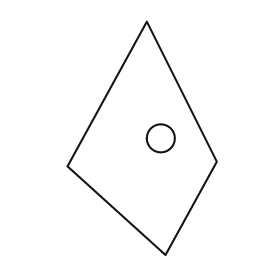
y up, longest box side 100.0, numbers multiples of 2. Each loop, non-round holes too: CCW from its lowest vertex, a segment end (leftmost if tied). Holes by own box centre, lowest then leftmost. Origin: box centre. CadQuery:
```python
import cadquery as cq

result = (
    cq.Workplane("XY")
    .moveTo(10.0, -50.0)
    .lineTo(32.0, -10.0)
    .lineTo(2.0, 50.0)
    .lineTo(-32.0, -12.0)
    .close()
    .moveTo(8.0, 0.0)
    .circle(6.0)
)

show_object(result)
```